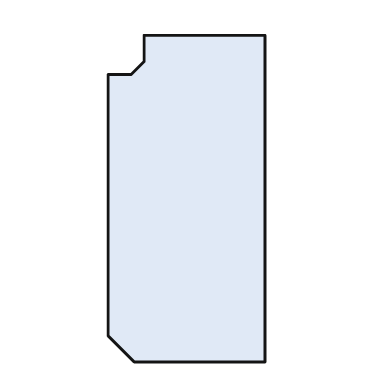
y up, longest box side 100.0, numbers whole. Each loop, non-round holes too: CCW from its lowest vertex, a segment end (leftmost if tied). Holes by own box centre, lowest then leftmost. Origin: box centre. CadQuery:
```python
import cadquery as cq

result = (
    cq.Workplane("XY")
    .moveTo(-16.0, -50.0)
    .lineTo(24.0, -50.0)
    .lineTo(24.0, 50.0)
    .lineTo(-13.0, 50.0)
    .lineTo(-13.0, 42.0)
    .lineTo(-17.0, 38.0)
    .lineTo(-24.0, 38.0)
    .lineTo(-24.0, -42.0)
    .close()
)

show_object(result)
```